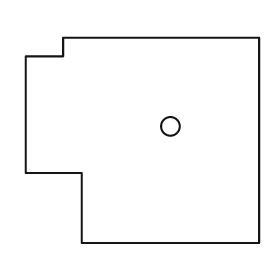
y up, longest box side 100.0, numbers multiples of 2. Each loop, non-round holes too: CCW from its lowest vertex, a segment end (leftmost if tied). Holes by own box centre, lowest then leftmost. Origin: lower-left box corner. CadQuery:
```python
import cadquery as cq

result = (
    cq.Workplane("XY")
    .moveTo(24.0, 0.0)
    .lineTo(100.0, 0.0)
    .lineTo(100.0, 88.0)
    .lineTo(16.0, 88.0)
    .lineTo(16.0, 80.0)
    .lineTo(0.0, 80.0)
    .lineTo(0.0, 30.0)
    .lineTo(24.0, 30.0)
    .close()
    .moveTo(62.0, 50.0)
    .circle(4.0)
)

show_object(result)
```